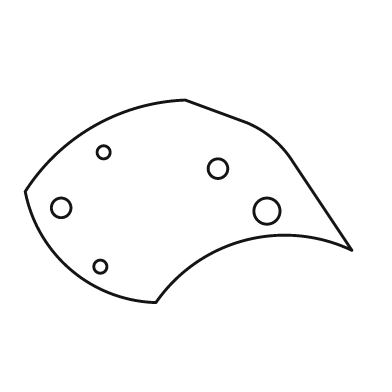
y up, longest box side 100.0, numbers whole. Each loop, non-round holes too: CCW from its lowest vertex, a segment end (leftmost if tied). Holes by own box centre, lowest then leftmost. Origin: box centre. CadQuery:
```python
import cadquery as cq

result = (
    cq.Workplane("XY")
    .moveTo(-10.0, -31.0)
    .threePointArc((17.0, -12.0), (50.0, -15.0))
    .lineTo(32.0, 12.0)
    .threePointArc((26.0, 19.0), (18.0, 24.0))
    .lineTo(-1.0, 31.0)
    .threePointArc((-29.0, 23.0), (-50.0, 3.0))
    .threePointArc((-36.0, -21.0), (-10.0, -31.0))
    .close()
    .moveTo(-27.0, -20.0)
    .circle(2.0)
    .moveTo(24.0, -3.0)
    .circle(4.0)
    .moveTo(-39.0, -2.0)
    .circle(3.0)
    .moveTo(9.0, 10.0)
    .circle(3.0)
    .moveTo(-26.0, 15.0)
    .circle(2.0)
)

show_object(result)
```